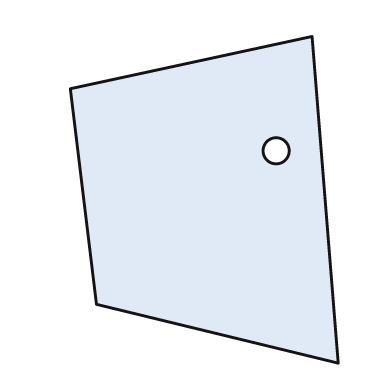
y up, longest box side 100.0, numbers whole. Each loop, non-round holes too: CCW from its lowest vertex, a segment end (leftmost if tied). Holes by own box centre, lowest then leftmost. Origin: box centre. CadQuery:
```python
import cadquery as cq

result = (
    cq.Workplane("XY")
    .moveTo(41.0, -50.0)
    .lineTo(33.0, 50.0)
    .lineTo(-41.0, 34.0)
    .lineTo(-33.0, -32.0)
    .close()
    .moveTo(22.0, 15.0)
    .circle(4.0)
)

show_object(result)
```